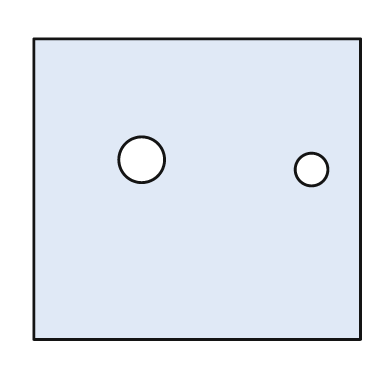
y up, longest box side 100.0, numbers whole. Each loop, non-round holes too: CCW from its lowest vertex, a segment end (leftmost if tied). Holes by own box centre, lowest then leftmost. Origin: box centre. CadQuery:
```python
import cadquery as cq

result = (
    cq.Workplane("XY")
    .moveTo(-50.0, -46.0)
    .lineTo(50.0, -46.0)
    .lineTo(50.0, 46.0)
    .lineTo(-50.0, 46.0)
    .close()
    .moveTo(35.0, 6.0)
    .circle(5.0)
    .moveTo(-17.0, 9.0)
    .circle(7.0)
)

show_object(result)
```